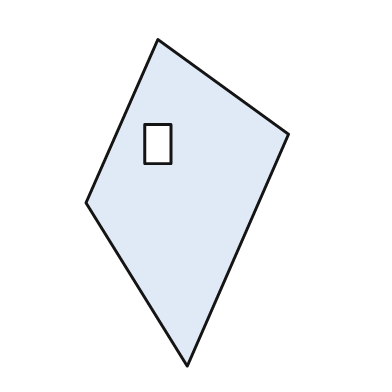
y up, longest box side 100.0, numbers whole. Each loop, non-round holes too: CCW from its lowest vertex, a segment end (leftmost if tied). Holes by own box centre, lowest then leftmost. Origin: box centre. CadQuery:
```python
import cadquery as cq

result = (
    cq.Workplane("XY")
    .moveTo(0.0, -50.0)
    .lineTo(31.0, 21.0)
    .lineTo(-9.0, 50.0)
    .lineTo(-31.0, 0.0)
    .close()
    .moveTo(-13.0, 12.0)
    .lineTo(-5.0, 12.0)
    .lineTo(-5.0, 24.0)
    .lineTo(-13.0, 24.0)
    .close()
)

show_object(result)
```